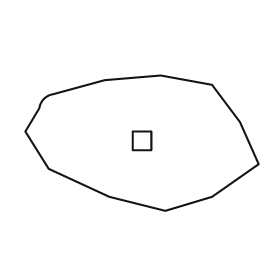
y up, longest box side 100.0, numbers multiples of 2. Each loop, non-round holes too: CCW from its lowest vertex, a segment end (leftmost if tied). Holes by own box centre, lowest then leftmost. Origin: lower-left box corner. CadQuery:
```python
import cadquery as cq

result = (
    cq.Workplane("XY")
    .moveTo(60.0, 0.0)
    .lineTo(80.0, 6.0)
    .lineTo(100.0, 20.0)
    .lineTo(92.0, 38.0)
    .lineTo(80.0, 54.0)
    .lineTo(58.0, 58.0)
    .lineTo(34.0, 56.0)
    .lineTo(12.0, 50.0)
    .threePointArc((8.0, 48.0), (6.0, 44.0))
    .lineTo(0.0, 34.0)
    .lineTo(10.0, 18.0)
    .lineTo(36.0, 6.0)
    .close()
    .moveTo(46.0, 26.0)
    .lineTo(54.0, 26.0)
    .lineTo(54.0, 34.0)
    .lineTo(46.0, 34.0)
    .close()
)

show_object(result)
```